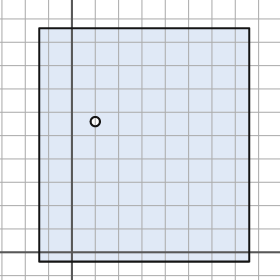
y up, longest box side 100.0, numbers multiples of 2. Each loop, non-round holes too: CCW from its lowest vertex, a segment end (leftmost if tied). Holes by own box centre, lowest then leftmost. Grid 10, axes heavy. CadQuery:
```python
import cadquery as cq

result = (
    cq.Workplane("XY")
    .moveTo(-14.0, -4.0)
    .lineTo(76.0, -4.0)
    .lineTo(76.0, 96.0)
    .lineTo(-14.0, 96.0)
    .close()
    .moveTo(10.0, 56.0)
    .circle(2.0)
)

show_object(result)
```